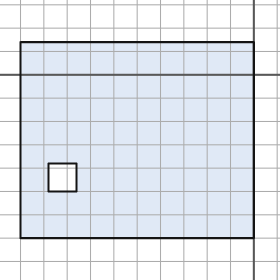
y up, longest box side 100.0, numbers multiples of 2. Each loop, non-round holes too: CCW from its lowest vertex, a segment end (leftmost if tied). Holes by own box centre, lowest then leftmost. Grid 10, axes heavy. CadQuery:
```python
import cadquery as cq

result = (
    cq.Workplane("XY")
    .moveTo(-100.0, -70.0)
    .lineTo(0.0, -70.0)
    .lineTo(0.0, 14.0)
    .lineTo(-100.0, 14.0)
    .close()
    .moveTo(-88.0, -50.0)
    .lineTo(-76.0, -50.0)
    .lineTo(-76.0, -38.0)
    .lineTo(-88.0, -38.0)
    .close()
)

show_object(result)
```